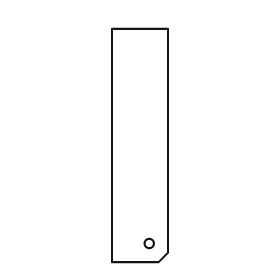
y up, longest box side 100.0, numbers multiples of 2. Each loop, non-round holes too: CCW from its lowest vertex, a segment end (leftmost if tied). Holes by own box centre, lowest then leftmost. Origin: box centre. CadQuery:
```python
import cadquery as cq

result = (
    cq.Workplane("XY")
    .moveTo(-12.0, -50.0)
    .lineTo(8.0, -50.0)
    .lineTo(12.0, -46.0)
    .lineTo(12.0, 50.0)
    .lineTo(-12.0, 50.0)
    .close()
    .moveTo(4.0, -42.0)
    .circle(2.0)
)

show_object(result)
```